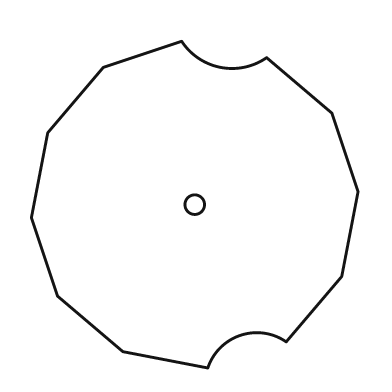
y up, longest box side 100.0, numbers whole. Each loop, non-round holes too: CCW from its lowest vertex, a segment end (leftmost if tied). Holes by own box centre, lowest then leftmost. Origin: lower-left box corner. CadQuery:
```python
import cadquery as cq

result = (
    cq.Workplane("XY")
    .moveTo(54.0, 0.0)
    .threePointArc((64.0, 10.0), (78.0, 8.0))
    .lineTo(95.0, 28.0)
    .lineTo(100.0, 54.0)
    .lineTo(92.0, 78.0)
    .lineTo(72.0, 95.0)
    .threePointArc((58.0, 92.0), (46.0, 100.0))
    .lineTo(22.0, 92.0)
    .lineTo(5.0, 72.0)
    .lineTo(0.0, 46.0)
    .lineTo(8.0, 22.0)
    .lineTo(28.0, 5.0)
    .close()
    .moveTo(50.0, 50.0)
    .circle(3.0)
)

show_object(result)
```